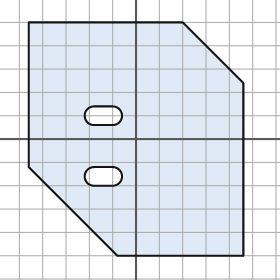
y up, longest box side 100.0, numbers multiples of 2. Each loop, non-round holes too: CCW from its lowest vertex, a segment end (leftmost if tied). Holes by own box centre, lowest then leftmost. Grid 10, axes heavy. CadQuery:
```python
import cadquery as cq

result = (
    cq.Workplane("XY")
    .moveTo(-8.0, -50.0)
    .lineTo(46.0, -50.0)
    .lineTo(46.0, 24.0)
    .lineTo(20.0, 50.0)
    .lineTo(-46.0, 50.0)
    .lineTo(-46.0, -12.0)
    .close()
    .moveTo(-18.0, -20.0)
    .lineTo(-10.0, -20.0)
    .threePointArc((-6.0, -16.0), (-10.0, -12.0))
    .lineTo(-18.0, -12.0)
    .threePointArc((-22.0, -16.0), (-18.0, -20.0))
    .close()
    .moveTo(-18.0, 6.0)
    .lineTo(-10.0, 6.0)
    .threePointArc((-6.0, 10.0), (-10.0, 14.0))
    .lineTo(-18.0, 14.0)
    .threePointArc((-22.0, 10.0), (-18.0, 6.0))
    .close()
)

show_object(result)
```